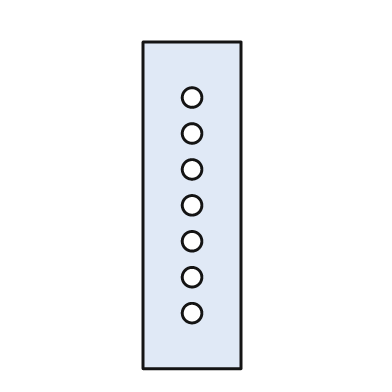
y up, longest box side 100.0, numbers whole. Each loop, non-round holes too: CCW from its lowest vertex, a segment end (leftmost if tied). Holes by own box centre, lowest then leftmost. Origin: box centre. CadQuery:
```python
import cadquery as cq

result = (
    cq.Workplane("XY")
    .moveTo(-15.0, -50.0)
    .lineTo(15.0, -50.0)
    .lineTo(15.0, 50.0)
    .lineTo(-15.0, 50.0)
    .close()
    .moveTo(0.0, -33.0)
    .circle(3.0)
    .moveTo(0.0, -22.0)
    .circle(3.0)
    .moveTo(0.0, -11.0)
    .circle(3.0)
    .moveTo(0.0, 0.0)
    .circle(3.0)
    .moveTo(0.0, 11.0)
    .circle(3.0)
    .moveTo(0.0, 22.0)
    .circle(3.0)
    .moveTo(0.0, 33.0)
    .circle(3.0)
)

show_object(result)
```